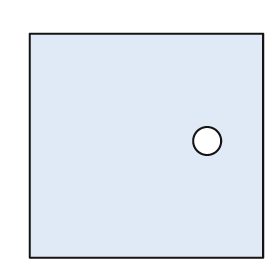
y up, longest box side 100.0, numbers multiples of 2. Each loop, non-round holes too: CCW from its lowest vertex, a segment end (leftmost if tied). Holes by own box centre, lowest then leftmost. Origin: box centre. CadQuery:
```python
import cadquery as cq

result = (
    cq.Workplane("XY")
    .moveTo(-50.0, -48.0)
    .lineTo(50.0, -48.0)
    .lineTo(50.0, 48.0)
    .lineTo(-50.0, 48.0)
    .close()
    .moveTo(26.0, 2.0)
    .circle(6.0)
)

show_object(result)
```